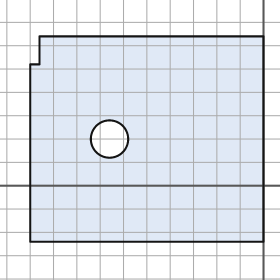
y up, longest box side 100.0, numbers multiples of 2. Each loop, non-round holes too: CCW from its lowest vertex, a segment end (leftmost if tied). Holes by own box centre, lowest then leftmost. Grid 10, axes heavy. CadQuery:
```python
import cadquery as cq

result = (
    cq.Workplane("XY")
    .moveTo(-100.0, -24.0)
    .lineTo(0.0, -24.0)
    .lineTo(0.0, 64.0)
    .lineTo(-96.0, 64.0)
    .lineTo(-96.0, 52.0)
    .lineTo(-100.0, 52.0)
    .close()
    .moveTo(-66.0, 20.0)
    .circle(8.0)
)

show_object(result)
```